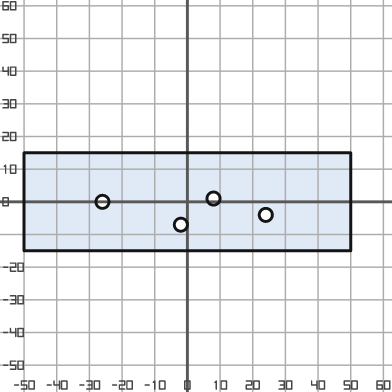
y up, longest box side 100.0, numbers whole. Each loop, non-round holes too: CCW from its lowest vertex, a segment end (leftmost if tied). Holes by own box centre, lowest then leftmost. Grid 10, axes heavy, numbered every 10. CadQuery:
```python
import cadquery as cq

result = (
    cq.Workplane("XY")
    .moveTo(-50.0, -15.0)
    .lineTo(50.0, -15.0)
    .lineTo(50.0, 15.0)
    .lineTo(-50.0, 15.0)
    .close()
    .moveTo(-2.0, -7.0)
    .circle(2.0)
    .moveTo(24.0, -4.0)
    .circle(2.0)
    .moveTo(-26.0, 0.0)
    .circle(2.0)
    .moveTo(8.0, 1.0)
    .circle(2.0)
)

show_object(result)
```